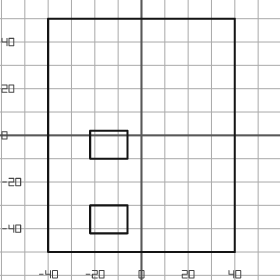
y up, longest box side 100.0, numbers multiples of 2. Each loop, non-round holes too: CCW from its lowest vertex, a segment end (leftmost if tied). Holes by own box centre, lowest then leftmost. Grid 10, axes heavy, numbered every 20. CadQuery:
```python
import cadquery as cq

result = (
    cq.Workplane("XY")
    .moveTo(-40.0, -50.0)
    .lineTo(40.0, -50.0)
    .lineTo(40.0, 50.0)
    .lineTo(-40.0, 50.0)
    .close()
    .moveTo(-22.0, -42.0)
    .lineTo(-6.0, -42.0)
    .lineTo(-6.0, -30.0)
    .lineTo(-22.0, -30.0)
    .close()
    .moveTo(-22.0, -10.0)
    .lineTo(-6.0, -10.0)
    .lineTo(-6.0, 2.0)
    .lineTo(-22.0, 2.0)
    .close()
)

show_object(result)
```